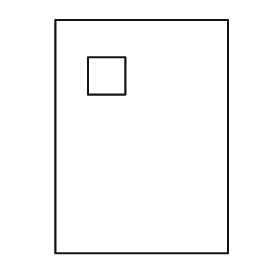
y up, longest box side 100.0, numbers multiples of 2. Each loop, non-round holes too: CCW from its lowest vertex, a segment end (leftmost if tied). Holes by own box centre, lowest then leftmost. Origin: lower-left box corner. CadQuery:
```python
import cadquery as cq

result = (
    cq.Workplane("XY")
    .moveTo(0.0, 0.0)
    .lineTo(74.0, 0.0)
    .lineTo(74.0, 100.0)
    .lineTo(0.0, 100.0)
    .close()
    .moveTo(14.0, 68.0)
    .lineTo(30.0, 68.0)
    .lineTo(30.0, 84.0)
    .lineTo(14.0, 84.0)
    .close()
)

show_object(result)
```